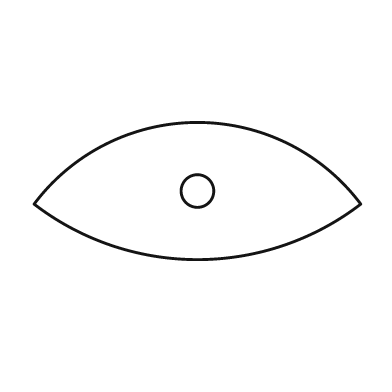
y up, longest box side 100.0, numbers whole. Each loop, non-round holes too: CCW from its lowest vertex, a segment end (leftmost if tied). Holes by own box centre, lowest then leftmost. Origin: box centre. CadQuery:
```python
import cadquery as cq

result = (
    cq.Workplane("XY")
    .moveTo(-50.0, -4.0)
    .threePointArc((0.0, -21.0), (50.0, -4.0))
    .threePointArc((0.0, 21.0), (-50.0, -4.0))
    .close()
    .moveTo(0.0, 0.0)
    .circle(5.0)
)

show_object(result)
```